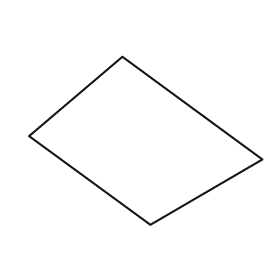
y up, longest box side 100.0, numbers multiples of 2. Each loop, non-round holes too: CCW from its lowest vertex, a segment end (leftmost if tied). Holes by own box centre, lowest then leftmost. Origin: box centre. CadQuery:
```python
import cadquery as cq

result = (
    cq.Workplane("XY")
    .moveTo(2.0, -36.0)
    .lineTo(50.0, -8.0)
    .lineTo(-10.0, 36.0)
    .lineTo(-50.0, 2.0)
    .close()
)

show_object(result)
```